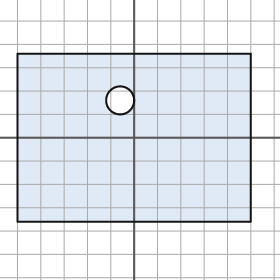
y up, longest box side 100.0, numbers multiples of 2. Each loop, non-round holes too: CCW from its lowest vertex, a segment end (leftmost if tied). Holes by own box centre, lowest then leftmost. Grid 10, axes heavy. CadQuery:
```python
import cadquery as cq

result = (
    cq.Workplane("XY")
    .moveTo(-50.0, -36.0)
    .lineTo(50.0, -36.0)
    .lineTo(50.0, 36.0)
    .lineTo(-50.0, 36.0)
    .close()
    .moveTo(-6.0, 16.0)
    .circle(6.0)
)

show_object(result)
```